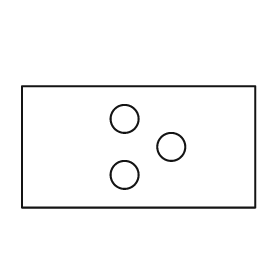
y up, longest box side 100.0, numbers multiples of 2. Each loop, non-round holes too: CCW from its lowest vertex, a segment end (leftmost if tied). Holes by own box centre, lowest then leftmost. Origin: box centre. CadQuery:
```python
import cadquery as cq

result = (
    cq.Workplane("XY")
    .moveTo(-50.0, -26.0)
    .lineTo(50.0, -26.0)
    .lineTo(50.0, 26.0)
    .lineTo(-50.0, 26.0)
    .close()
    .moveTo(-6.0, -12.0)
    .circle(6.0)
    .moveTo(14.0, 0.0)
    .circle(6.0)
    .moveTo(-6.0, 12.0)
    .circle(6.0)
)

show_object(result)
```